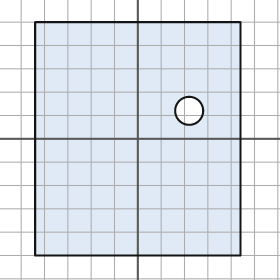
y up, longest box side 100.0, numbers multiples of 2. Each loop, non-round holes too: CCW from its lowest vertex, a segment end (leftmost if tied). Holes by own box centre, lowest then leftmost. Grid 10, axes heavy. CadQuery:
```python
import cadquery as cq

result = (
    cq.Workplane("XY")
    .moveTo(-44.0, -50.0)
    .lineTo(44.0, -50.0)
    .lineTo(44.0, 50.0)
    .lineTo(-44.0, 50.0)
    .close()
    .moveTo(22.0, 12.0)
    .circle(6.0)
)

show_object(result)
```